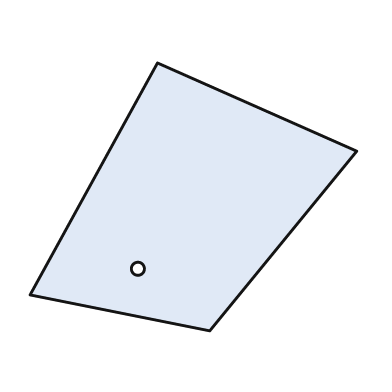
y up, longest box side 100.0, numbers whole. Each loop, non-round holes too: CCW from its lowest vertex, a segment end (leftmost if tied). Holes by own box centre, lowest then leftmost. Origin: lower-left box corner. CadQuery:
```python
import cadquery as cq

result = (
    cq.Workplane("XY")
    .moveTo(55.0, 0.0)
    .lineTo(100.0, 55.0)
    .lineTo(39.0, 82.0)
    .lineTo(0.0, 11.0)
    .close()
    .moveTo(33.0, 19.0)
    .circle(2.0)
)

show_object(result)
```